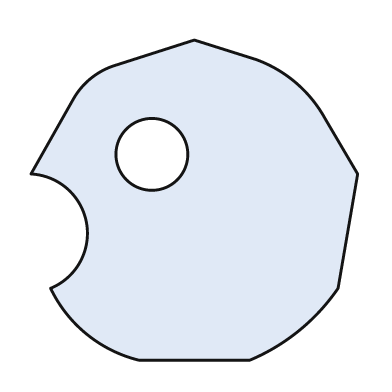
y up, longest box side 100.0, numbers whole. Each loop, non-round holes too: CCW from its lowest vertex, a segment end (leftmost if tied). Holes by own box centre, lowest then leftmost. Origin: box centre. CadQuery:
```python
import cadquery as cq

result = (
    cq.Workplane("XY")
    .moveTo(-17.0, -49.0)
    .lineTo(17.0, -49.0)
    .threePointArc((32.0, -40.0), (44.0, -27.0))
    .lineTo(50.0, 8.0)
    .lineTo(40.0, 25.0)
    .threePointArc((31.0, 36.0), (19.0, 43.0))
    .lineTo(0.0, 49.0)
    .lineTo(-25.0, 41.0)
    .threePointArc((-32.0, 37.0), (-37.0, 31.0))
    .lineTo(-50.0, 8.0)
    .threePointArc((-33.0, -7.0), (-44.0, -27.0))
    .threePointArc((-33.0, -41.0), (-17.0, -49.0))
    .close()
    .moveTo(-13.0, 14.0)
    .circle(11.0)
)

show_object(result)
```